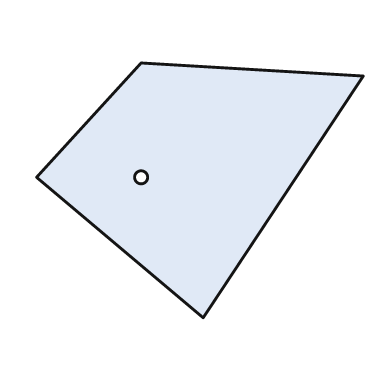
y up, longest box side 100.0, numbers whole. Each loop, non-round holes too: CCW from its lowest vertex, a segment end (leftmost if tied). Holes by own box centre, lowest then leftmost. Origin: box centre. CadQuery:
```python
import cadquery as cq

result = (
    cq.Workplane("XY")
    .moveTo(1.0, -39.0)
    .lineTo(50.0, 35.0)
    .lineTo(-18.0, 39.0)
    .lineTo(-50.0, 4.0)
    .close()
    .moveTo(-18.0, 4.0)
    .circle(2.0)
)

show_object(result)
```